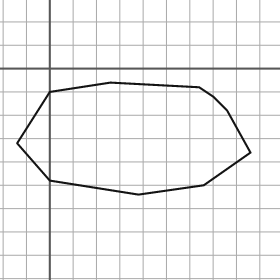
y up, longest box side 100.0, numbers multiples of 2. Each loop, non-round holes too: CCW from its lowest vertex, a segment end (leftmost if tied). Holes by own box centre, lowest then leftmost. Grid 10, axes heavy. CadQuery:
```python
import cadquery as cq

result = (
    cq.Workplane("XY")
    .moveTo(38.0, -54.0)
    .lineTo(66.0, -50.0)
    .lineTo(86.0, -36.0)
    .lineTo(76.0, -18.0)
    .lineTo(70.0, -12.0)
    .lineTo(64.0, -8.0)
    .lineTo(26.0, -6.0)
    .lineTo(0.0, -10.0)
    .lineTo(-14.0, -32.0)
    .lineTo(0.0, -48.0)
    .close()
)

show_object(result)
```